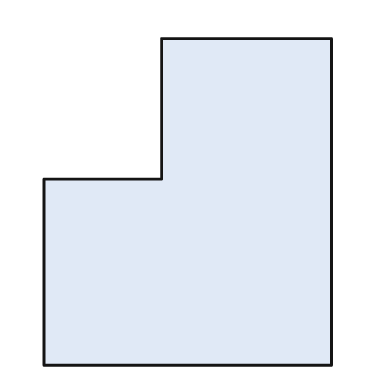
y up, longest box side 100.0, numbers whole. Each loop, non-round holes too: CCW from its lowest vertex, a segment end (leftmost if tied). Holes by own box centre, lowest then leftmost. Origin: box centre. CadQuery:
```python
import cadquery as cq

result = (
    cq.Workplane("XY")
    .moveTo(-44.0, -50.0)
    .lineTo(44.0, -50.0)
    .lineTo(44.0, 50.0)
    .lineTo(-8.0, 50.0)
    .lineTo(-8.0, 7.0)
    .lineTo(-44.0, 7.0)
    .close()
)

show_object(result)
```